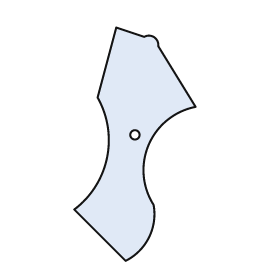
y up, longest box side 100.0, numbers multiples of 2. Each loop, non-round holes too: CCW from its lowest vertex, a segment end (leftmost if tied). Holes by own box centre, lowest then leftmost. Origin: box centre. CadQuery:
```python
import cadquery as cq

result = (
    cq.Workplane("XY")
    .moveTo(-4.0, -50.0)
    .threePointArc((6.0, -40.0), (8.0, -26.0))
    .threePointArc((6.0, 0.0), (26.0, 16.0))
    .lineTo(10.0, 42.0)
    .threePointArc((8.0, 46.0), (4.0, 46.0))
    .lineTo(-8.0, 50.0)
    .lineTo(-16.0, 20.0)
    .threePointArc((-12.0, -6.0), (-26.0, -28.0))
    .close()
    .moveTo(0.0, 4.0)
    .circle(2.0)
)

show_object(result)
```